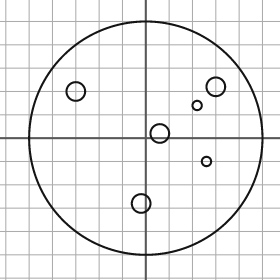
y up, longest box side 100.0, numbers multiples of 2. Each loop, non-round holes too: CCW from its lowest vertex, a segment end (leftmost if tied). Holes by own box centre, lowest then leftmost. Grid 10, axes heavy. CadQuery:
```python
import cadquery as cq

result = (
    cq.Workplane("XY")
    .moveTo(0.0, 0.0)
    .circle(50.0)
    .moveTo(-2.0, -28.0)
    .circle(4.0)
    .moveTo(26.0, -10.0)
    .circle(2.0)
    .moveTo(6.0, 2.0)
    .circle(4.0)
    .moveTo(22.0, 14.0)
    .circle(2.0)
    .moveTo(-30.0, 20.0)
    .circle(4.0)
    .moveTo(30.0, 22.0)
    .circle(4.0)
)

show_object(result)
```